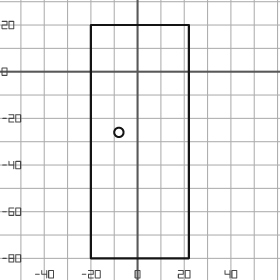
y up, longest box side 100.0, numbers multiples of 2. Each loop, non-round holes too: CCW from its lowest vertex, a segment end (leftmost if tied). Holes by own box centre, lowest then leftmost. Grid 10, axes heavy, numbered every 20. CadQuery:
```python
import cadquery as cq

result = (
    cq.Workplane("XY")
    .moveTo(-20.0, -80.0)
    .lineTo(22.0, -80.0)
    .lineTo(22.0, 20.0)
    .lineTo(-20.0, 20.0)
    .close()
    .moveTo(-8.0, -26.0)
    .circle(2.0)
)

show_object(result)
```